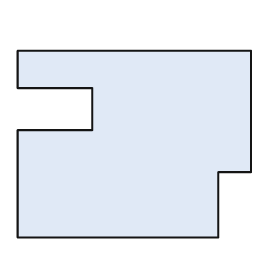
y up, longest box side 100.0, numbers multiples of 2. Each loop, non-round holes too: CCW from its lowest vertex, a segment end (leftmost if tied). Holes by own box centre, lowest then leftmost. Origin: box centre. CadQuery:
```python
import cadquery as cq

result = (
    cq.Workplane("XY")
    .moveTo(-50.0, -40.0)
    .lineTo(36.0, -40.0)
    .lineTo(36.0, -12.0)
    .lineTo(50.0, -12.0)
    .lineTo(50.0, 40.0)
    .lineTo(-50.0, 40.0)
    .lineTo(-50.0, 24.0)
    .lineTo(-18.0, 24.0)
    .lineTo(-18.0, 6.0)
    .lineTo(-50.0, 6.0)
    .close()
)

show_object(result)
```